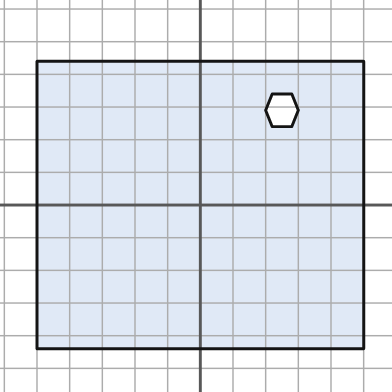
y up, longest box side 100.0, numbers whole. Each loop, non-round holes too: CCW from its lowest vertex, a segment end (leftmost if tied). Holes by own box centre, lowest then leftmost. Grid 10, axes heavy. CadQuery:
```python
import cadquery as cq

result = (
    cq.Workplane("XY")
    .moveTo(-50.0, -44.0)
    .lineTo(50.0, -44.0)
    .lineTo(50.0, 44.0)
    .lineTo(-50.0, 44.0)
    .close()
    .moveTo(22.0, 24.0)
    .lineTo(28.0, 24.0)
    .lineTo(30.0, 29.0)
    .lineTo(28.0, 34.0)
    .lineTo(22.0, 34.0)
    .lineTo(20.0, 29.0)
    .close()
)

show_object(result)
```